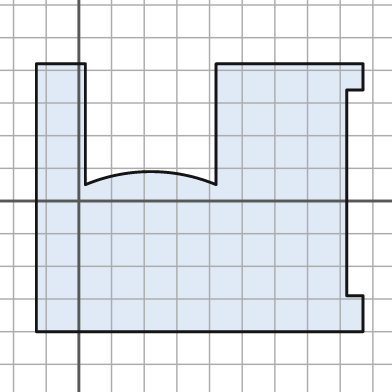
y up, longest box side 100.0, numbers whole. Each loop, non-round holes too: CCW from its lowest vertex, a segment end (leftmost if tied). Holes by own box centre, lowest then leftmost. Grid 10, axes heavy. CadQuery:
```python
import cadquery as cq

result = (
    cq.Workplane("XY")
    .moveTo(-13.0, -40.0)
    .lineTo(87.0, -40.0)
    .lineTo(87.0, -29.0)
    .lineTo(82.0, -29.0)
    .lineTo(82.0, 34.0)
    .lineTo(87.0, 34.0)
    .lineTo(87.0, 42.0)
    .lineTo(42.0, 42.0)
    .lineTo(42.0, 5.0)
    .threePointArc((22.0, 9.0), (2.0, 5.0))
    .lineTo(2.0, 42.0)
    .lineTo(-13.0, 42.0)
    .close()
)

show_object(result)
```